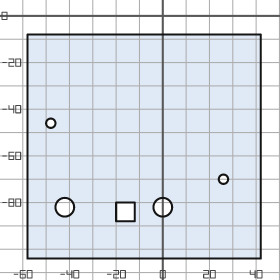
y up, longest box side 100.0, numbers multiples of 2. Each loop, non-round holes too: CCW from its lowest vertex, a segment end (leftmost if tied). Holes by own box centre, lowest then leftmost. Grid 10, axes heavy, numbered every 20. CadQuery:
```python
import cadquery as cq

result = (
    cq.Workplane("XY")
    .moveTo(-58.0, -104.0)
    .lineTo(42.0, -104.0)
    .lineTo(42.0, -8.0)
    .lineTo(-58.0, -8.0)
    .close()
    .moveTo(-20.0, -88.0)
    .lineTo(-12.0, -88.0)
    .lineTo(-12.0, -80.0)
    .lineTo(-20.0, -80.0)
    .close()
    .moveTo(-42.0, -82.0)
    .circle(4.0)
    .moveTo(0.0, -82.0)
    .circle(4.0)
    .moveTo(26.0, -70.0)
    .circle(2.0)
    .moveTo(-48.0, -46.0)
    .circle(2.0)
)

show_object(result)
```